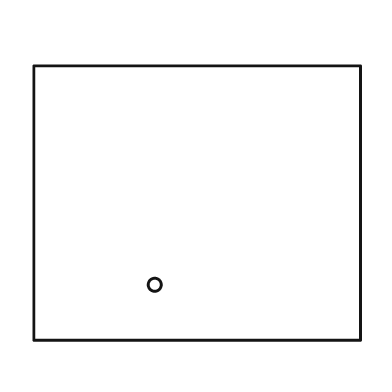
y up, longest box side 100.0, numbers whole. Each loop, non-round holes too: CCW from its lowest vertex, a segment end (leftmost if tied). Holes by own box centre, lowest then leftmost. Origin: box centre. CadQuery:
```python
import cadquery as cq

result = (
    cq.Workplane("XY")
    .moveTo(-50.0, -42.0)
    .lineTo(50.0, -42.0)
    .lineTo(50.0, 42.0)
    .lineTo(-50.0, 42.0)
    .close()
    .moveTo(-13.0, -25.0)
    .circle(2.0)
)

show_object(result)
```